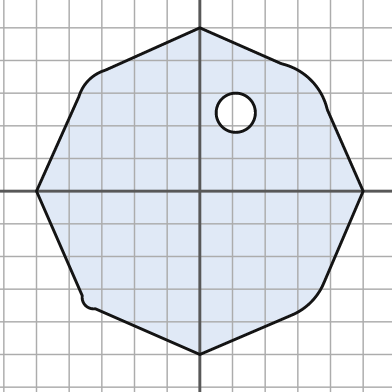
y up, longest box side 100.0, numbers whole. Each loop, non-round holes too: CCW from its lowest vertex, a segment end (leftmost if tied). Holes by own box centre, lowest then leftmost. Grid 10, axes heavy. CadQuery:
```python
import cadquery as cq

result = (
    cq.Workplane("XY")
    .moveTo(0.0, -50.0)
    .lineTo(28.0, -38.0)
    .threePointArc((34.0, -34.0), (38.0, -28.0))
    .lineTo(50.0, 0.0)
    .lineTo(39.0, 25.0)
    .threePointArc((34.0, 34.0), (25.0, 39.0))
    .lineTo(0.0, 50.0)
    .lineTo(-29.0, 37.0)
    .threePointArc((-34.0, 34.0), (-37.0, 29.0))
    .lineTo(-50.0, 0.0)
    .lineTo(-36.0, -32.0)
    .threePointArc((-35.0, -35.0), (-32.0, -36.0))
    .close()
    .moveTo(11.0, 24.0)
    .circle(6.0)
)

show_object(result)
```